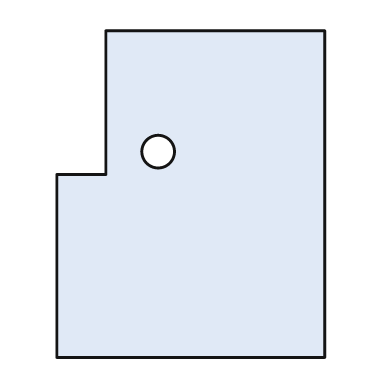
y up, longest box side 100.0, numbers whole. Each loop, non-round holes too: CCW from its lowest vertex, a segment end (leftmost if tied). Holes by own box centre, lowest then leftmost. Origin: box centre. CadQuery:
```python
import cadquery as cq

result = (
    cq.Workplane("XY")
    .moveTo(-41.0, -50.0)
    .lineTo(41.0, -50.0)
    .lineTo(41.0, 50.0)
    .lineTo(-26.0, 50.0)
    .lineTo(-26.0, 6.0)
    .lineTo(-41.0, 6.0)
    .close()
    .moveTo(-10.0, 13.0)
    .circle(5.0)
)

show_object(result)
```